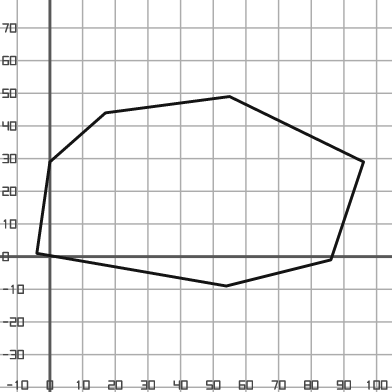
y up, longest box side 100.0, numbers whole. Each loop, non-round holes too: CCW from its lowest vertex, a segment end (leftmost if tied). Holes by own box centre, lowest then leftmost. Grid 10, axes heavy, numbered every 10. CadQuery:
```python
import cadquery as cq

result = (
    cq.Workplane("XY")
    .moveTo(54.0, -9.0)
    .lineTo(86.0, -1.0)
    .lineTo(96.0, 29.0)
    .lineTo(55.0, 49.0)
    .lineTo(17.0, 44.0)
    .lineTo(0.0, 29.0)
    .lineTo(-4.0, 1.0)
    .close()
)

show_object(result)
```